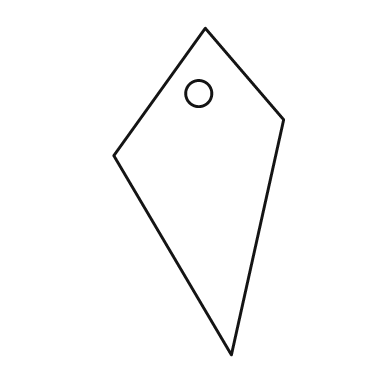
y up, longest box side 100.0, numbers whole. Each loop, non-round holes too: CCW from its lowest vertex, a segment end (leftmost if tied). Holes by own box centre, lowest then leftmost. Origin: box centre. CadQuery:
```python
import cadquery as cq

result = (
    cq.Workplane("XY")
    .moveTo(10.0, -50.0)
    .lineTo(26.0, 22.0)
    .lineTo(2.0, 50.0)
    .lineTo(-26.0, 11.0)
    .close()
    .moveTo(0.0, 30.0)
    .circle(4.0)
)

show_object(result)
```